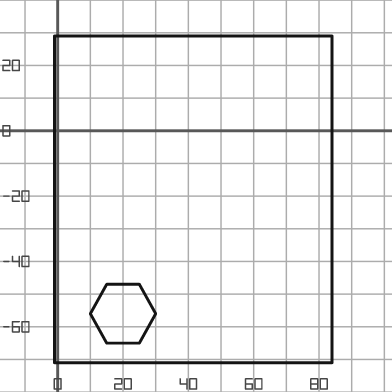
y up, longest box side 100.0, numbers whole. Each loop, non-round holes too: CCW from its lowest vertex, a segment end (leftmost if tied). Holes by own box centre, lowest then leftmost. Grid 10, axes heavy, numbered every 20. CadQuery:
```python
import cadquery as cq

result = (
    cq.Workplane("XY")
    .moveTo(-1.0, -71.0)
    .lineTo(84.0, -71.0)
    .lineTo(84.0, 29.0)
    .lineTo(-1.0, 29.0)
    .close()
    .moveTo(15.0, -65.0)
    .lineTo(25.0, -65.0)
    .lineTo(30.0, -56.0)
    .lineTo(25.0, -47.0)
    .lineTo(15.0, -47.0)
    .lineTo(10.0, -56.0)
    .close()
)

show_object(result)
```